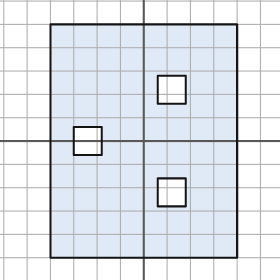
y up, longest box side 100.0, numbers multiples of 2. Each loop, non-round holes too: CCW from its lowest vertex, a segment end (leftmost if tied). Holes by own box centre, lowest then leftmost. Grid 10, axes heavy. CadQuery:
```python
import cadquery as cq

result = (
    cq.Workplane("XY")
    .moveTo(-40.0, -50.0)
    .lineTo(40.0, -50.0)
    .lineTo(40.0, 50.0)
    .lineTo(-40.0, 50.0)
    .close()
    .moveTo(6.0, -28.0)
    .lineTo(18.0, -28.0)
    .lineTo(18.0, -16.0)
    .lineTo(6.0, -16.0)
    .close()
    .moveTo(-30.0, -6.0)
    .lineTo(-18.0, -6.0)
    .lineTo(-18.0, 6.0)
    .lineTo(-30.0, 6.0)
    .close()
    .moveTo(6.0, 16.0)
    .lineTo(18.0, 16.0)
    .lineTo(18.0, 28.0)
    .lineTo(6.0, 28.0)
    .close()
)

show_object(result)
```